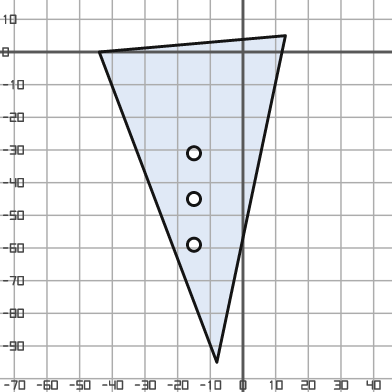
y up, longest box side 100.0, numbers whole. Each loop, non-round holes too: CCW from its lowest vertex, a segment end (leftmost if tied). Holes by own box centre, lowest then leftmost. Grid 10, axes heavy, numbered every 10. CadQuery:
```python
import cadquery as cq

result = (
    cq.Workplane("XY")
    .moveTo(-8.0, -95.0)
    .lineTo(13.0, 5.0)
    .lineTo(-44.0, 0.0)
    .close()
    .moveTo(-15.0, -59.0)
    .circle(2.0)
    .moveTo(-15.0, -45.0)
    .circle(2.0)
    .moveTo(-15.0, -31.0)
    .circle(2.0)
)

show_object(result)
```